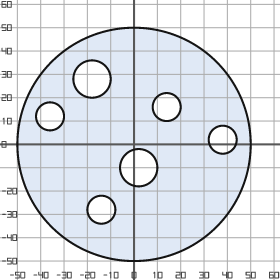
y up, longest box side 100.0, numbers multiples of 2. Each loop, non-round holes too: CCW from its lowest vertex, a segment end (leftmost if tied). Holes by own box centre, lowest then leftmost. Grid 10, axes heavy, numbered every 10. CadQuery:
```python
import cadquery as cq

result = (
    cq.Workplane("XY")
    .moveTo(0.0, 0.0)
    .circle(50.0)
    .moveTo(-14.0, -28.0)
    .circle(6.0)
    .moveTo(2.0, -10.0)
    .circle(8.0)
    .moveTo(38.0, 2.0)
    .circle(6.0)
    .moveTo(-36.0, 12.0)
    .circle(6.0)
    .moveTo(14.0, 16.0)
    .circle(6.0)
    .moveTo(-18.0, 28.0)
    .circle(8.0)
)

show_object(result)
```